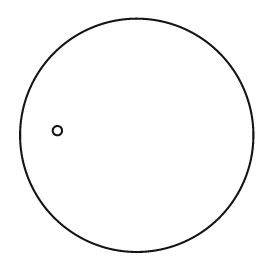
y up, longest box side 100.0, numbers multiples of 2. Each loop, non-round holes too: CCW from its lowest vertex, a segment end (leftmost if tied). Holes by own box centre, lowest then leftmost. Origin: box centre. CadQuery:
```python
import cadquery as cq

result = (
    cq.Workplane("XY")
    .moveTo(0.0, 0.0)
    .circle(50.0)
    .moveTo(-34.0, 2.0)
    .circle(2.0)
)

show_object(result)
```